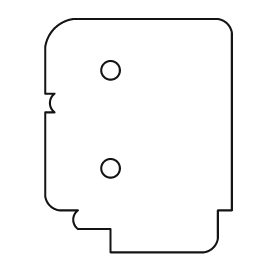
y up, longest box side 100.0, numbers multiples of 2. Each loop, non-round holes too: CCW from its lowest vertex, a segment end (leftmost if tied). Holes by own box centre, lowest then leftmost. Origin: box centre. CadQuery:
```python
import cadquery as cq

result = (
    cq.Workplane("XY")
    .moveTo(-12.0, -50.0)
    .lineTo(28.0, -50.0)
    .threePointArc((32.0, -48.0), (34.0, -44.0))
    .lineTo(34.0, -32.0)
    .lineTo(40.0, -32.0)
    .lineTo(40.0, 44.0)
    .threePointArc((38.0, 48.0), (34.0, 50.0))
    .lineTo(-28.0, 50.0)
    .threePointArc((-36.0, 46.0), (-40.0, 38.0))
    .lineTo(-40.0, 18.0)
    .lineTo(-36.0, 18.0)
    .threePointArc((-38.0, 14.0), (-36.0, 10.0))
    .lineTo(-40.0, 10.0)
    .lineTo(-40.0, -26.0)
    .threePointArc((-38.0, -30.0), (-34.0, -32.0))
    .lineTo(-26.0, -32.0)
    .threePointArc((-28.0, -36.0), (-26.0, -40.0))
    .lineTo(-12.0, -40.0)
    .close()
    .moveTo(-12.0, -14.0)
    .circle(4.0)
    .moveTo(-12.0, 28.0)
    .circle(4.0)
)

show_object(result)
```